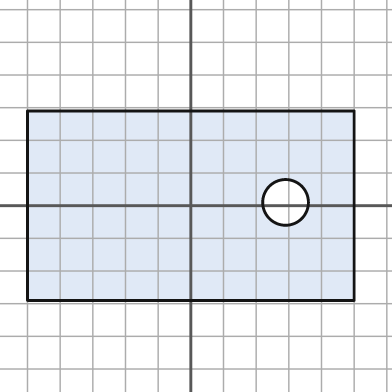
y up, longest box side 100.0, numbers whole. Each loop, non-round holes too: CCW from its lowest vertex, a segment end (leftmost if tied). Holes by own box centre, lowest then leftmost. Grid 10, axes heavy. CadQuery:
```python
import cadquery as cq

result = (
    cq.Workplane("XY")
    .moveTo(-50.0, -29.0)
    .lineTo(50.0, -29.0)
    .lineTo(50.0, 29.0)
    .lineTo(-50.0, 29.0)
    .close()
    .moveTo(29.0, 1.0)
    .circle(7.0)
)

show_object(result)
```